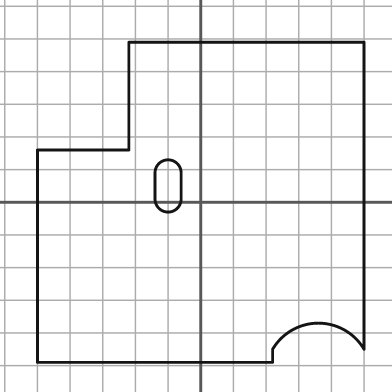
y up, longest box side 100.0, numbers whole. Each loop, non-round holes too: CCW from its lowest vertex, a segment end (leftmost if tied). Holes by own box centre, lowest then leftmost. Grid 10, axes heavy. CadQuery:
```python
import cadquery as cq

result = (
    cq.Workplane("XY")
    .moveTo(-50.0, -49.0)
    .lineTo(22.0, -49.0)
    .lineTo(22.0, -45.0)
    .threePointArc((36.0, -37.0), (50.0, -45.0))
    .lineTo(50.0, 49.0)
    .lineTo(-22.0, 49.0)
    .lineTo(-22.0, 16.0)
    .lineTo(-50.0, 16.0)
    .close()
    .moveTo(-14.0, 1.0)
    .threePointArc((-10.0, -3.0), (-6.0, 1.0))
    .lineTo(-6.0, 9.0)
    .threePointArc((-10.0, 13.0), (-14.0, 9.0))
    .close()
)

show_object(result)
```